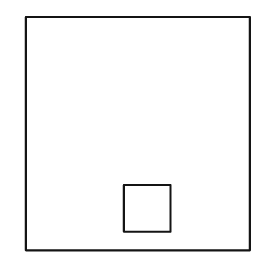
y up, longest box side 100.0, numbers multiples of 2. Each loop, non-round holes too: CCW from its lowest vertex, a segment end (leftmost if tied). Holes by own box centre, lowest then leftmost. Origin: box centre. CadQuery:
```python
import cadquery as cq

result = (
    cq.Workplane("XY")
    .moveTo(-48.0, -50.0)
    .lineTo(48.0, -50.0)
    .lineTo(48.0, 50.0)
    .lineTo(-48.0, 50.0)
    .close()
    .moveTo(-6.0, -42.0)
    .lineTo(14.0, -42.0)
    .lineTo(14.0, -22.0)
    .lineTo(-6.0, -22.0)
    .close()
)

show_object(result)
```